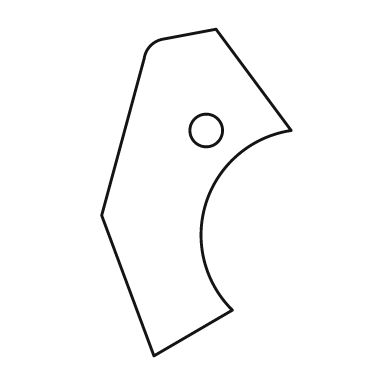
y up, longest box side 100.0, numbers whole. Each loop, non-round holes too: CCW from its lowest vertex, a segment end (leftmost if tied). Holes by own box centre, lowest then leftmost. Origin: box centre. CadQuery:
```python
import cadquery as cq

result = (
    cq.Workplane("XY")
    .moveTo(-13.0, -50.0)
    .lineTo(11.0, -36.0)
    .threePointArc((3.0, -3.0), (29.0, 19.0))
    .lineTo(6.0, 50.0)
    .lineTo(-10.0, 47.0)
    .threePointArc((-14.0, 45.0), (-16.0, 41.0))
    .lineTo(-29.0, -7.0)
    .close()
    .moveTo(3.0, 19.0)
    .circle(5.0)
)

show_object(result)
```